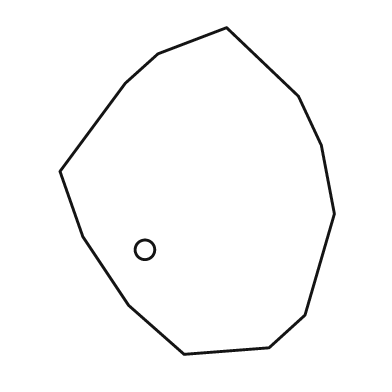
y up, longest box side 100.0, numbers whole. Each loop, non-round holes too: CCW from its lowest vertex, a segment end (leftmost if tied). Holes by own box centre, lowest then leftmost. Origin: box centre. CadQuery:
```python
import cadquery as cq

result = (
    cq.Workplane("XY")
    .moveTo(-4.0, -50.0)
    .lineTo(22.0, -48.0)
    .lineTo(33.0, -38.0)
    .lineTo(42.0, -7.0)
    .lineTo(38.0, 14.0)
    .lineTo(31.0, 29.0)
    .lineTo(9.0, 50.0)
    .lineTo(-12.0, 42.0)
    .lineTo(-22.0, 33.0)
    .lineTo(-42.0, 6.0)
    .lineTo(-35.0, -14.0)
    .lineTo(-21.0, -35.0)
    .close()
    .moveTo(-16.0, -18.0)
    .circle(3.0)
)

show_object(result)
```